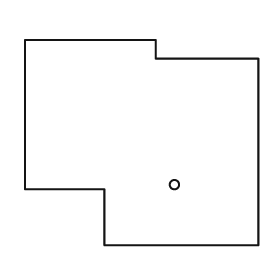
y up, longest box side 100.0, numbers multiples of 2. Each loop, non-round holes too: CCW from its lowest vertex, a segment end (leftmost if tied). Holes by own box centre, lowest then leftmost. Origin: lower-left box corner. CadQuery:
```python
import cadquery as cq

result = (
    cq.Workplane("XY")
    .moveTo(34.0, 0.0)
    .lineTo(100.0, 0.0)
    .lineTo(100.0, 80.0)
    .lineTo(56.0, 80.0)
    .lineTo(56.0, 88.0)
    .lineTo(0.0, 88.0)
    .lineTo(0.0, 24.0)
    .lineTo(34.0, 24.0)
    .close()
    .moveTo(64.0, 26.0)
    .circle(2.0)
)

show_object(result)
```